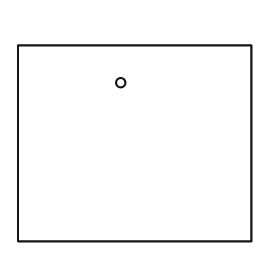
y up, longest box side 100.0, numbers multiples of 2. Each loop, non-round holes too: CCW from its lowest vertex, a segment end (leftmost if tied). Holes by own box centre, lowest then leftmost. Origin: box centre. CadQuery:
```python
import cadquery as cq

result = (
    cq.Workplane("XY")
    .moveTo(-50.0, -42.0)
    .lineTo(50.0, -42.0)
    .lineTo(50.0, 42.0)
    .lineTo(-50.0, 42.0)
    .close()
    .moveTo(-6.0, 26.0)
    .circle(2.0)
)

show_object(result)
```